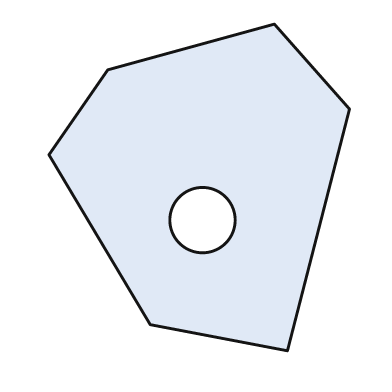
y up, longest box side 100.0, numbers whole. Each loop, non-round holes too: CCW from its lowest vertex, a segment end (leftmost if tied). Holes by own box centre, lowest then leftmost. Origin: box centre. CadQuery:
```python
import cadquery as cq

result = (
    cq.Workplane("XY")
    .moveTo(27.0, -50.0)
    .lineTo(46.0, 24.0)
    .lineTo(23.0, 50.0)
    .lineTo(-28.0, 36.0)
    .lineTo(-46.0, 10.0)
    .lineTo(-15.0, -42.0)
    .close()
    .moveTo(1.0, -10.0)
    .circle(10.0)
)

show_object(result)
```